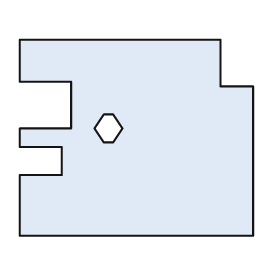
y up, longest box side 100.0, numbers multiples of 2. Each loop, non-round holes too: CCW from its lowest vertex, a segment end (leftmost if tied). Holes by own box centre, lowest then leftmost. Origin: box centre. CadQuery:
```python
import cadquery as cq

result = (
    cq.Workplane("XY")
    .moveTo(-50.0, -42.0)
    .lineTo(50.0, -42.0)
    .lineTo(50.0, 22.0)
    .lineTo(36.0, 22.0)
    .lineTo(36.0, 42.0)
    .lineTo(-50.0, 42.0)
    .lineTo(-50.0, 24.0)
    .lineTo(-28.0, 24.0)
    .lineTo(-28.0, 4.0)
    .lineTo(-50.0, 4.0)
    .lineTo(-50.0, -4.0)
    .lineTo(-32.0, -4.0)
    .lineTo(-32.0, -16.0)
    .lineTo(-50.0, -16.0)
    .close()
    .moveTo(-14.0, -2.0)
    .lineTo(-10.0, -2.0)
    .lineTo(-6.0, 4.0)
    .lineTo(-10.0, 10.0)
    .lineTo(-14.0, 10.0)
    .lineTo(-18.0, 4.0)
    .close()
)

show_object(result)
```